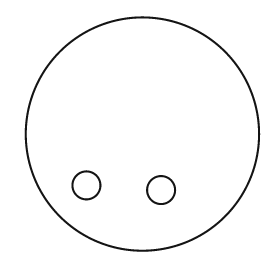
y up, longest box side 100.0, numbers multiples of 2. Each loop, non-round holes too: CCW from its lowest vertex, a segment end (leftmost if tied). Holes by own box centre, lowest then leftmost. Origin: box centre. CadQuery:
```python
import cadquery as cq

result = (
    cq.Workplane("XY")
    .moveTo(0.0, 0.0)
    .circle(50.0)
    .moveTo(8.0, -24.0)
    .circle(6.0)
    .moveTo(-24.0, -22.0)
    .circle(6.0)
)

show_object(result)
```